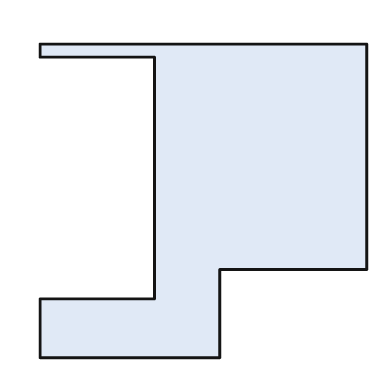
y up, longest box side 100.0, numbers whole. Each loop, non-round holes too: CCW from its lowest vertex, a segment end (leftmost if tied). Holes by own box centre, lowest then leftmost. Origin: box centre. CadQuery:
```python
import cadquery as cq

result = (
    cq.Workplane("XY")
    .moveTo(-50.0, -48.0)
    .lineTo(5.0, -48.0)
    .lineTo(5.0, -21.0)
    .lineTo(50.0, -21.0)
    .lineTo(50.0, 48.0)
    .lineTo(-50.0, 48.0)
    .lineTo(-50.0, 44.0)
    .lineTo(-15.0, 44.0)
    .lineTo(-15.0, -30.0)
    .lineTo(-50.0, -30.0)
    .close()
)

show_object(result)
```